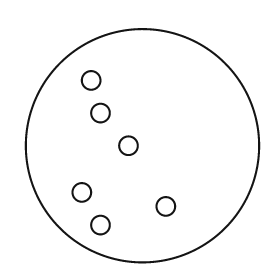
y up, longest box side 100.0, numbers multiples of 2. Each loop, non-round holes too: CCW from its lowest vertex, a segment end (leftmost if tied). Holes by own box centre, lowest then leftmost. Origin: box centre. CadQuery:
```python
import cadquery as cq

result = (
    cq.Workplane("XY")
    .moveTo(0.0, 0.0)
    .circle(50.0)
    .moveTo(-18.0, -34.0)
    .circle(4.0)
    .moveTo(10.0, -26.0)
    .circle(4.0)
    .moveTo(-26.0, -20.0)
    .circle(4.0)
    .moveTo(-6.0, 0.0)
    .circle(4.0)
    .moveTo(-18.0, 14.0)
    .circle(4.0)
    .moveTo(-22.0, 28.0)
    .circle(4.0)
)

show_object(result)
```